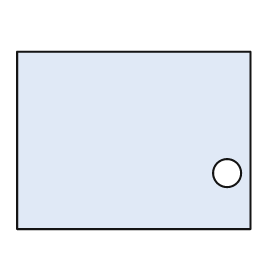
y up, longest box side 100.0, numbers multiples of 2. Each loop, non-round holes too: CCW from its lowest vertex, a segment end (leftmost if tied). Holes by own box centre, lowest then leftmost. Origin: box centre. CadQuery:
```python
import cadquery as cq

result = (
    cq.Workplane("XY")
    .moveTo(-50.0, -38.0)
    .lineTo(50.0, -38.0)
    .lineTo(50.0, 38.0)
    .lineTo(-50.0, 38.0)
    .close()
    .moveTo(40.0, -14.0)
    .circle(6.0)
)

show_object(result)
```